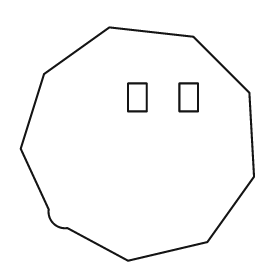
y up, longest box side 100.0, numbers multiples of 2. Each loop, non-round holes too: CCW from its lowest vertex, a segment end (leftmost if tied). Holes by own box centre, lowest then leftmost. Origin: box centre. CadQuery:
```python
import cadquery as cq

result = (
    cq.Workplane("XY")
    .moveTo(-4.0, -50.0)
    .lineTo(30.0, -42.0)
    .lineTo(50.0, -14.0)
    .lineTo(48.0, 22.0)
    .lineTo(24.0, 46.0)
    .lineTo(-12.0, 50.0)
    .lineTo(-40.0, 30.0)
    .lineTo(-50.0, -2.0)
    .lineTo(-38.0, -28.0)
    .threePointArc((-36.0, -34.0), (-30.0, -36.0))
    .close()
    .moveTo(-4.0, 14.0)
    .lineTo(4.0, 14.0)
    .lineTo(4.0, 26.0)
    .lineTo(-4.0, 26.0)
    .close()
    .moveTo(18.0, 14.0)
    .lineTo(26.0, 14.0)
    .lineTo(26.0, 26.0)
    .lineTo(18.0, 26.0)
    .close()
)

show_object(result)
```